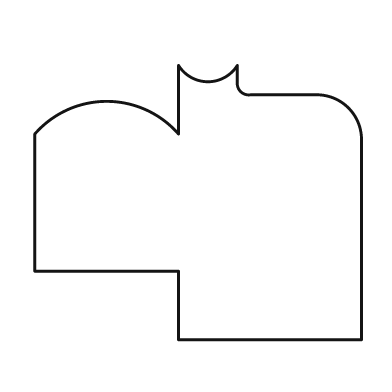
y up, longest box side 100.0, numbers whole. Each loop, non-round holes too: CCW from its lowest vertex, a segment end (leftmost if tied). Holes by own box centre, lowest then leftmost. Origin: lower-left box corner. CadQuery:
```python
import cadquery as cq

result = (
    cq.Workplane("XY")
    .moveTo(44.0, 0.0)
    .lineTo(100.0, 0.0)
    .lineTo(100.0, 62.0)
    .threePointArc((96.0, 71.0), (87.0, 75.0))
    .lineTo(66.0, 75.0)
    .threePointArc((63.0, 76.0), (62.0, 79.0))
    .lineTo(62.0, 84.0)
    .threePointArc((53.0, 79.0), (44.0, 84.0))
    .lineTo(44.0, 63.0)
    .threePointArc((22.0, 73.0), (0.0, 63.0))
    .lineTo(0.0, 21.0)
    .lineTo(44.0, 21.0)
    .close()
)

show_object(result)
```